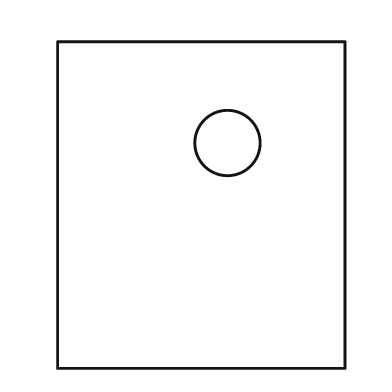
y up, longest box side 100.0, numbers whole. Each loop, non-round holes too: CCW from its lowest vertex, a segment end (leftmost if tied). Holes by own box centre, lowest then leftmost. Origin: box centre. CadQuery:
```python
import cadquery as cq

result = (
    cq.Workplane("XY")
    .moveTo(-44.0, -50.0)
    .lineTo(44.0, -50.0)
    .lineTo(44.0, 50.0)
    .lineTo(-44.0, 50.0)
    .close()
    .moveTo(8.0, 19.0)
    .circle(10.0)
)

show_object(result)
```